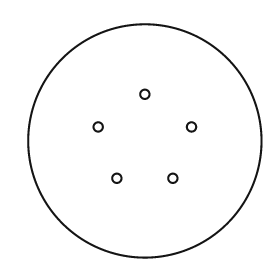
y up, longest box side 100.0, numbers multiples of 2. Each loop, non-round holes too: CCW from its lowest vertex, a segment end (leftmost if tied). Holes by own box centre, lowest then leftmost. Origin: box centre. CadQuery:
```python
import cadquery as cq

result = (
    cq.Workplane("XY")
    .moveTo(0.0, 0.0)
    .circle(50.0)
    .moveTo(-12.0, -16.0)
    .circle(2.0)
    .moveTo(12.0, -16.0)
    .circle(2.0)
    .moveTo(-20.0, 6.0)
    .circle(2.0)
    .moveTo(20.0, 6.0)
    .circle(2.0)
    .moveTo(0.0, 20.0)
    .circle(2.0)
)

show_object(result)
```